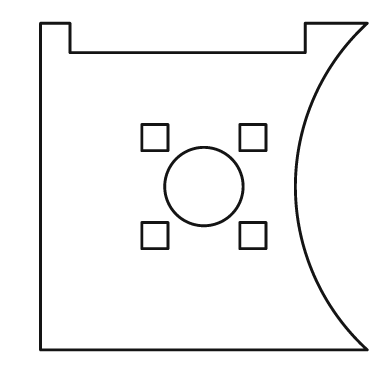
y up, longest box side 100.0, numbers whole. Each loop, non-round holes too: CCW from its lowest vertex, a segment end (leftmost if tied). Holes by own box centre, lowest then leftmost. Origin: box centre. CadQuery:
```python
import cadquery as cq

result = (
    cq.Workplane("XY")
    .moveTo(-50.0, -50.0)
    .lineTo(50.0, -50.0)
    .threePointArc((28.0, 0.0), (50.0, 50.0))
    .lineTo(31.0, 50.0)
    .lineTo(31.0, 41.0)
    .lineTo(-41.0, 41.0)
    .lineTo(-41.0, 50.0)
    .lineTo(-50.0, 50.0)
    .close()
    .moveTo(-19.0, -19.0)
    .lineTo(-11.0, -19.0)
    .lineTo(-11.0, -11.0)
    .lineTo(-19.0, -11.0)
    .close()
    .moveTo(11.0, -19.0)
    .lineTo(19.0, -19.0)
    .lineTo(19.0, -11.0)
    .lineTo(11.0, -11.0)
    .close()
    .moveTo(0.0, 0.0)
    .circle(12.0)
    .moveTo(-19.0, 11.0)
    .lineTo(-11.0, 11.0)
    .lineTo(-11.0, 19.0)
    .lineTo(-19.0, 19.0)
    .close()
    .moveTo(11.0, 11.0)
    .lineTo(19.0, 11.0)
    .lineTo(19.0, 19.0)
    .lineTo(11.0, 19.0)
    .close()
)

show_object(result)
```